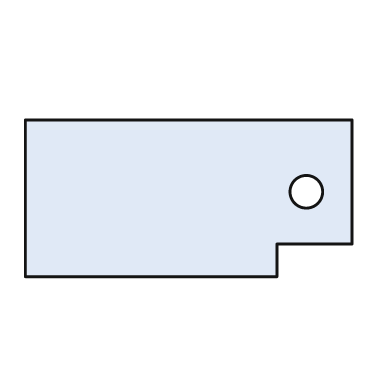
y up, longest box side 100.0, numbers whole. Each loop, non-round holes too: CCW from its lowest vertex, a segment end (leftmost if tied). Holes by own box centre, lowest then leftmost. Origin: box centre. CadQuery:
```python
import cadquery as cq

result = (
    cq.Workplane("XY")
    .moveTo(-50.0, -24.0)
    .lineTo(27.0, -24.0)
    .lineTo(27.0, -14.0)
    .lineTo(50.0, -14.0)
    .lineTo(50.0, 24.0)
    .lineTo(-50.0, 24.0)
    .close()
    .moveTo(36.0, 2.0)
    .circle(5.0)
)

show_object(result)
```